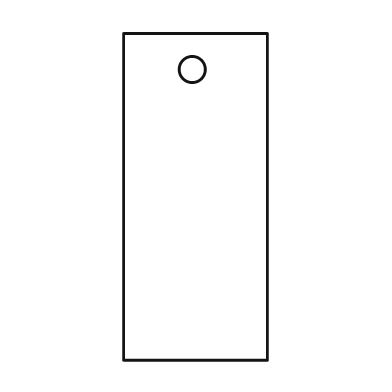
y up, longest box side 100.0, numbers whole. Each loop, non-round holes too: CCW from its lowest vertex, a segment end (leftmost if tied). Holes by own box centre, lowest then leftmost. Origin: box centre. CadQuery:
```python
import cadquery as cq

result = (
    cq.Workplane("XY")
    .moveTo(-22.0, -50.0)
    .lineTo(22.0, -50.0)
    .lineTo(22.0, 50.0)
    .lineTo(-22.0, 50.0)
    .close()
    .moveTo(-1.0, 39.0)
    .circle(4.0)
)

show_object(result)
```